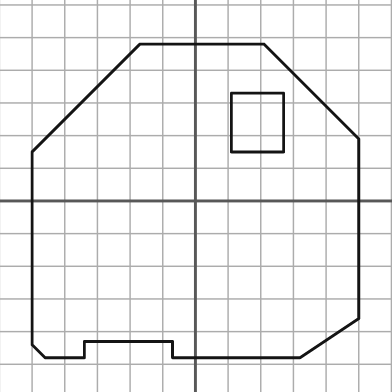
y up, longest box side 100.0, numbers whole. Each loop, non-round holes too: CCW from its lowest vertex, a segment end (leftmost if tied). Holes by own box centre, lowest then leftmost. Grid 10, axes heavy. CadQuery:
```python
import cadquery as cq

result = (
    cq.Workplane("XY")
    .moveTo(-46.0, -48.0)
    .lineTo(-34.0, -48.0)
    .lineTo(-34.0, -43.0)
    .lineTo(-7.0, -43.0)
    .lineTo(-7.0, -48.0)
    .lineTo(32.0, -48.0)
    .lineTo(50.0, -36.0)
    .lineTo(50.0, 19.0)
    .lineTo(21.0, 48.0)
    .lineTo(-17.0, 48.0)
    .lineTo(-50.0, 15.0)
    .lineTo(-50.0, -44.0)
    .close()
    .moveTo(11.0, 15.0)
    .lineTo(27.0, 15.0)
    .lineTo(27.0, 33.0)
    .lineTo(11.0, 33.0)
    .close()
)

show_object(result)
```